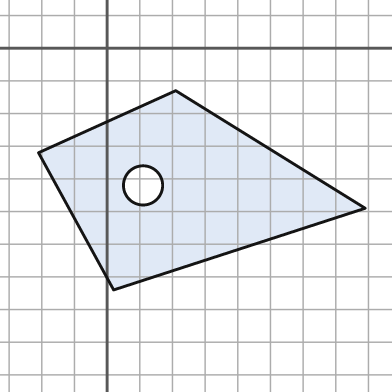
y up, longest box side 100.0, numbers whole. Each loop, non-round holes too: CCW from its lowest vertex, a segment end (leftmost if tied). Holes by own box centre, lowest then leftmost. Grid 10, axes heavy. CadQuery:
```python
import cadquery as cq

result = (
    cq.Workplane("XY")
    .moveTo(2.0, -74.0)
    .lineTo(79.0, -49.0)
    .lineTo(21.0, -13.0)
    .lineTo(-21.0, -32.0)
    .close()
    .moveTo(11.0, -42.0)
    .circle(6.0)
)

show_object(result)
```